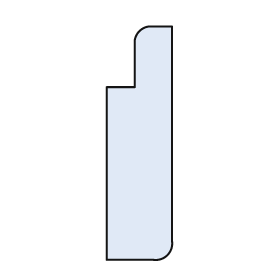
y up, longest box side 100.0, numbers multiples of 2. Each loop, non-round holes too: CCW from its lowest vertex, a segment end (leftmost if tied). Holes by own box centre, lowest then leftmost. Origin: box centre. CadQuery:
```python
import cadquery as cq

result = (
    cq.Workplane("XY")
    .moveTo(-14.0, -50.0)
    .lineTo(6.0, -50.0)
    .threePointArc((12.0, -48.0), (14.0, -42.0))
    .lineTo(14.0, 50.0)
    .lineTo(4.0, 50.0)
    .threePointArc((0.0, 48.0), (-2.0, 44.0))
    .lineTo(-2.0, 24.0)
    .lineTo(-14.0, 24.0)
    .close()
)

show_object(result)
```